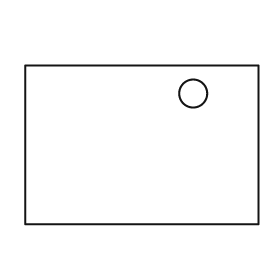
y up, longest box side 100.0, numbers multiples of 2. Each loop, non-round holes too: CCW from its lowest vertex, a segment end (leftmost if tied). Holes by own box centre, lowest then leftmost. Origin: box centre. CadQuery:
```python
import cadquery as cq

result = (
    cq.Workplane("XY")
    .moveTo(-50.0, -34.0)
    .lineTo(50.0, -34.0)
    .lineTo(50.0, 34.0)
    .lineTo(-50.0, 34.0)
    .close()
    .moveTo(22.0, 22.0)
    .circle(6.0)
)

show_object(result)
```